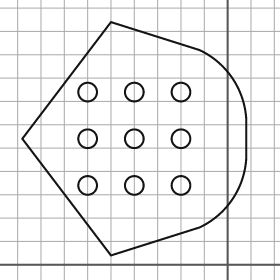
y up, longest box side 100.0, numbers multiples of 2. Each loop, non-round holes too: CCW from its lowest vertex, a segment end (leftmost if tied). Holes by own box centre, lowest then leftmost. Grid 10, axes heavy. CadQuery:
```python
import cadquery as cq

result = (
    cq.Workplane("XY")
    .moveTo(-50.0, 4.0)
    .lineTo(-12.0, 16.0)
    .threePointArc((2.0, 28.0), (8.0, 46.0))
    .lineTo(8.0, 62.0)
    .threePointArc((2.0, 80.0), (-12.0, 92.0))
    .lineTo(-50.0, 104.0)
    .lineTo(-88.0, 54.0)
    .close()
    .moveTo(-60.0, 34.0)
    .circle(4.0)
    .moveTo(-40.0, 34.0)
    .circle(4.0)
    .moveTo(-20.0, 34.0)
    .circle(4.0)
    .moveTo(-60.0, 54.0)
    .circle(4.0)
    .moveTo(-40.0, 54.0)
    .circle(4.0)
    .moveTo(-20.0, 54.0)
    .circle(4.0)
    .moveTo(-60.0, 74.0)
    .circle(4.0)
    .moveTo(-40.0, 74.0)
    .circle(4.0)
    .moveTo(-20.0, 74.0)
    .circle(4.0)
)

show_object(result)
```